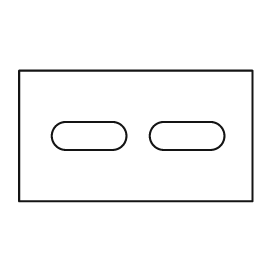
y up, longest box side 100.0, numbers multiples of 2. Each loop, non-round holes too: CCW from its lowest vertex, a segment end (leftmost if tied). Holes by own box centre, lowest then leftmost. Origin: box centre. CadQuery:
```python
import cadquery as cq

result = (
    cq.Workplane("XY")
    .moveTo(-50.0, -28.0)
    .lineTo(50.0, -28.0)
    .lineTo(50.0, 28.0)
    .lineTo(-50.0, 28.0)
    .close()
    .moveTo(-30.0, -6.0)
    .lineTo(-10.0, -6.0)
    .threePointArc((-4.0, 0.0), (-10.0, 6.0))
    .lineTo(-30.0, 6.0)
    .threePointArc((-36.0, 0.0), (-30.0, -6.0))
    .close()
    .moveTo(12.0, -6.0)
    .lineTo(32.0, -6.0)
    .threePointArc((38.0, 0.0), (32.0, 6.0))
    .lineTo(12.0, 6.0)
    .threePointArc((6.0, 0.0), (12.0, -6.0))
    .close()
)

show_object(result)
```